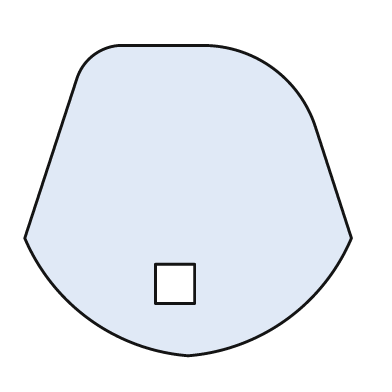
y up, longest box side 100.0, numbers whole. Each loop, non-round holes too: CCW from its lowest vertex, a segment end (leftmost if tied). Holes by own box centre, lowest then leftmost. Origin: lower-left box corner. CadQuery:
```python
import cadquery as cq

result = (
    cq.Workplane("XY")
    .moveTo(50.0, 0.0)
    .threePointArc((80.0, 11.0), (100.0, 36.0))
    .lineTo(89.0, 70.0)
    .threePointArc((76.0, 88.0), (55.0, 95.0))
    .lineTo(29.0, 95.0)
    .threePointArc((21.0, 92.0), (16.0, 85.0))
    .lineTo(0.0, 36.0)
    .threePointArc((20.0, 11.0), (50.0, 0.0))
    .close()
    .moveTo(40.0, 16.0)
    .lineTo(52.0, 16.0)
    .lineTo(52.0, 28.0)
    .lineTo(40.0, 28.0)
    .close()
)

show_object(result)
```